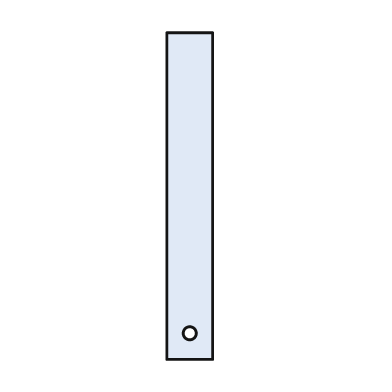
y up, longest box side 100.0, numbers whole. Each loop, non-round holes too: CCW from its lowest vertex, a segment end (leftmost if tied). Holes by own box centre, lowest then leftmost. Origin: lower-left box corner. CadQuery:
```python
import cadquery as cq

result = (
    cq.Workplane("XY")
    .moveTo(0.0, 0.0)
    .lineTo(14.0, 0.0)
    .lineTo(14.0, 100.0)
    .lineTo(0.0, 100.0)
    .close()
    .moveTo(7.0, 8.0)
    .circle(2.0)
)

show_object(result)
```